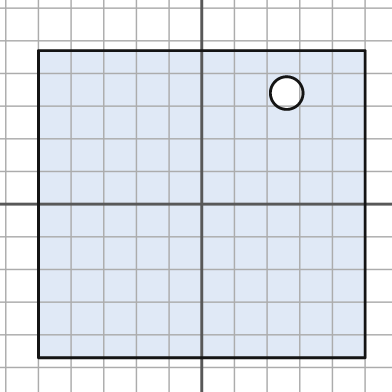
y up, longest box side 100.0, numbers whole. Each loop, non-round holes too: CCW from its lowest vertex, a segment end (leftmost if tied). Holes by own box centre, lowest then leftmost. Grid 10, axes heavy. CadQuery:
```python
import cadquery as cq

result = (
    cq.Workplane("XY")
    .moveTo(-50.0, -47.0)
    .lineTo(50.0, -47.0)
    .lineTo(50.0, 47.0)
    .lineTo(-50.0, 47.0)
    .close()
    .moveTo(26.0, 34.0)
    .circle(5.0)
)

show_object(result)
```